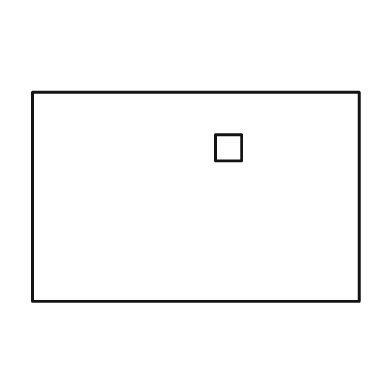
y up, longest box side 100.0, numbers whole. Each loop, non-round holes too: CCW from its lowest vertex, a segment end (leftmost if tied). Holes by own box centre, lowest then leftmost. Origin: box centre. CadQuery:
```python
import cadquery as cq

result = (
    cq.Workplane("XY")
    .moveTo(-50.0, -32.0)
    .lineTo(50.0, -32.0)
    .lineTo(50.0, 32.0)
    .lineTo(-50.0, 32.0)
    .close()
    .moveTo(6.0, 11.0)
    .lineTo(14.0, 11.0)
    .lineTo(14.0, 19.0)
    .lineTo(6.0, 19.0)
    .close()
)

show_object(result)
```